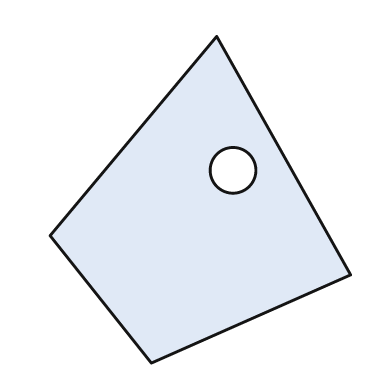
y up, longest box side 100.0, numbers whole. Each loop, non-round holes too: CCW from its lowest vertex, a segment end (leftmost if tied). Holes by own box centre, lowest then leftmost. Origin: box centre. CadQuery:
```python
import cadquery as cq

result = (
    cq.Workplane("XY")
    .moveTo(-15.0, -50.0)
    .lineTo(46.0, -23.0)
    .lineTo(5.0, 50.0)
    .lineTo(-46.0, -11.0)
    .close()
    .moveTo(10.0, 9.0)
    .circle(7.0)
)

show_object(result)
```